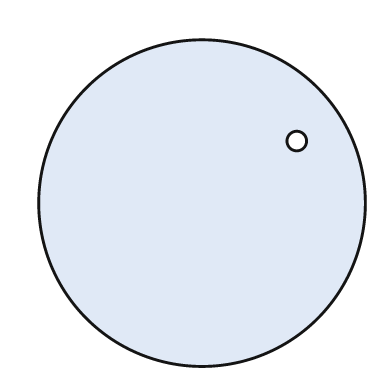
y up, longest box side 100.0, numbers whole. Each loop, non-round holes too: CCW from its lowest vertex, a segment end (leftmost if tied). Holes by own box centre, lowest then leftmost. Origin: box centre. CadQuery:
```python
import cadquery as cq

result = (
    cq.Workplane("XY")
    .moveTo(0.0, 0.0)
    .circle(50.0)
    .moveTo(29.0, 19.0)
    .circle(3.0)
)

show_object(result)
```